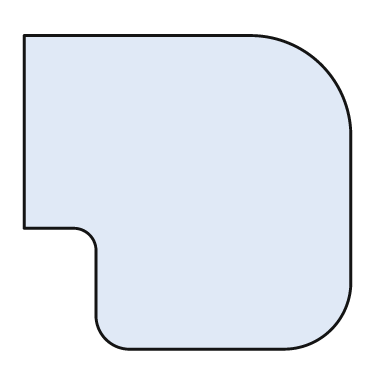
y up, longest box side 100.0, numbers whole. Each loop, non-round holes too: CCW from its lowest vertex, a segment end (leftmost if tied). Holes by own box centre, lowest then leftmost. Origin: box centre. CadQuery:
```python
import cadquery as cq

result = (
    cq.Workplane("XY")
    .moveTo(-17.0, -48.0)
    .lineTo(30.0, -48.0)
    .threePointArc((44.0, -42.0), (50.0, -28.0))
    .lineTo(50.0, 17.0)
    .threePointArc((41.0, 39.0), (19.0, 48.0))
    .lineTo(-50.0, 48.0)
    .lineTo(-50.0, -11.0)
    .lineTo(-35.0, -11.0)
    .threePointArc((-30.0, -13.0), (-28.0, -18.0))
    .lineTo(-28.0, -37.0)
    .threePointArc((-25.0, -45.0), (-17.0, -48.0))
    .close()
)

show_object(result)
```